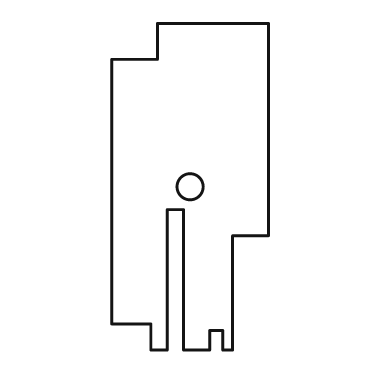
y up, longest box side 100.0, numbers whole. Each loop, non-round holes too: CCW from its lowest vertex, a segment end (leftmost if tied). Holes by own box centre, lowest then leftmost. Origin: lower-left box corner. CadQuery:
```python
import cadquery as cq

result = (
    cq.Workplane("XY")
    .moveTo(12.0, 0.0)
    .lineTo(17.0, 0.0)
    .lineTo(17.0, 43.0)
    .lineTo(22.0, 43.0)
    .lineTo(22.0, 0.0)
    .lineTo(30.0, 0.0)
    .lineTo(30.0, 6.0)
    .lineTo(34.0, 6.0)
    .lineTo(34.0, 0.0)
    .lineTo(37.0, 0.0)
    .lineTo(37.0, 35.0)
    .lineTo(48.0, 35.0)
    .lineTo(48.0, 100.0)
    .lineTo(14.0, 100.0)
    .lineTo(14.0, 89.0)
    .lineTo(0.0, 89.0)
    .lineTo(0.0, 8.0)
    .lineTo(12.0, 8.0)
    .close()
    .moveTo(24.0, 50.0)
    .circle(4.0)
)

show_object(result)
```